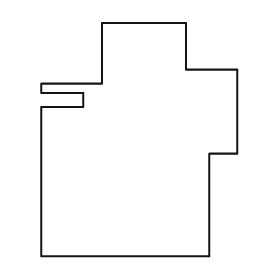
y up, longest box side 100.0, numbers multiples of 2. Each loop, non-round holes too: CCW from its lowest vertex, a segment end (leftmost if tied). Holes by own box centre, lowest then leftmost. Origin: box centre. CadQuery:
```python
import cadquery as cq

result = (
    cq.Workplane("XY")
    .moveTo(-42.0, -50.0)
    .lineTo(30.0, -50.0)
    .lineTo(30.0, -6.0)
    .lineTo(42.0, -6.0)
    .lineTo(42.0, 30.0)
    .lineTo(20.0, 30.0)
    .lineTo(20.0, 50.0)
    .lineTo(-16.0, 50.0)
    .lineTo(-16.0, 24.0)
    .lineTo(-42.0, 24.0)
    .lineTo(-42.0, 20.0)
    .lineTo(-24.0, 20.0)
    .lineTo(-24.0, 14.0)
    .lineTo(-42.0, 14.0)
    .close()
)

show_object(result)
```